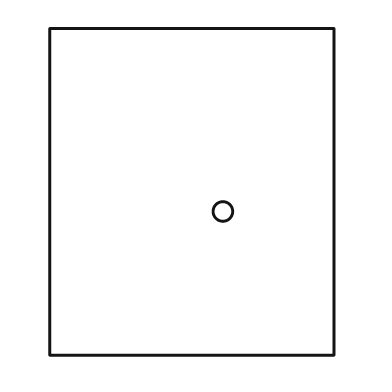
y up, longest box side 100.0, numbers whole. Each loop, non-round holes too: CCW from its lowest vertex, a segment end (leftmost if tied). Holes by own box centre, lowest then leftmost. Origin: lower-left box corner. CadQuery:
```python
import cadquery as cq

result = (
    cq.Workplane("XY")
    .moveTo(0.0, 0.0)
    .lineTo(87.0, 0.0)
    .lineTo(87.0, 100.0)
    .lineTo(0.0, 100.0)
    .close()
    .moveTo(53.0, 44.0)
    .circle(3.0)
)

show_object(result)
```